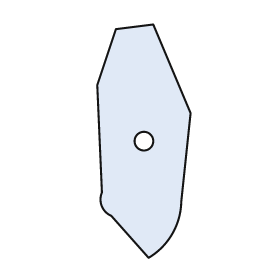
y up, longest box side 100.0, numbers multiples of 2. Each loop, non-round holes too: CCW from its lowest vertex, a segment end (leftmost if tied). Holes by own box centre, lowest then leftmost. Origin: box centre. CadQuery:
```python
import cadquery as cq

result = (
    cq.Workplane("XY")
    .moveTo(2.0, -50.0)
    .threePointArc((12.0, -40.0), (16.0, -26.0))
    .lineTo(20.0, 12.0)
    .lineTo(4.0, 50.0)
    .lineTo(-12.0, 48.0)
    .lineTo(-20.0, 24.0)
    .lineTo(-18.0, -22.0)
    .threePointArc((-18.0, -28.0), (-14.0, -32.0))
    .close()
    .moveTo(0.0, 0.0)
    .circle(4.0)
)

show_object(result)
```